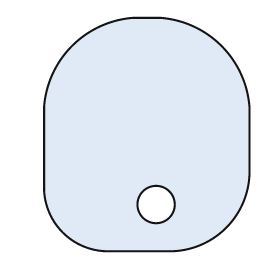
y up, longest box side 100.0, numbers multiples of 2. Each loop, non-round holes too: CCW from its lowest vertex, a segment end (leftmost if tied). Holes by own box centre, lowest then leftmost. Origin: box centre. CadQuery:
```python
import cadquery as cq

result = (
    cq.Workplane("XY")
    .moveTo(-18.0, -50.0)
    .lineTo(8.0, -50.0)
    .threePointArc((34.0, -40.0), (44.0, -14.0))
    .lineTo(44.0, 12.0)
    .threePointArc((32.0, 38.0), (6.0, 50.0))
    .lineTo(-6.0, 50.0)
    .threePointArc((-32.0, 38.0), (-44.0, 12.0))
    .lineTo(-44.0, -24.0)
    .threePointArc((-36.0, -42.0), (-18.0, -50.0))
    .close()
    .moveTo(4.0, -30.0)
    .circle(8.0)
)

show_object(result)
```